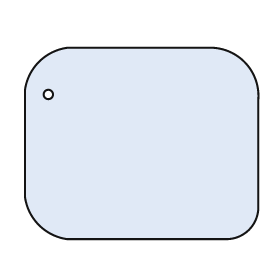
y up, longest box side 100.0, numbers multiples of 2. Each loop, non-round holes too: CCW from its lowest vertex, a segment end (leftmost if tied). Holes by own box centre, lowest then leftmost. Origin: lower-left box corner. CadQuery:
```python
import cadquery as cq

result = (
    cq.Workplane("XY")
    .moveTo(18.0, 0.0)
    .lineTo(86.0, 0.0)
    .threePointArc((96.0, 4.0), (100.0, 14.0))
    .lineTo(100.0, 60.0)
    .threePointArc((94.0, 76.0), (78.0, 82.0))
    .lineTo(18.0, 82.0)
    .threePointArc((6.0, 76.0), (0.0, 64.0))
    .lineTo(0.0, 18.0)
    .threePointArc((6.0, 6.0), (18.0, 0.0))
    .close()
    .moveTo(10.0, 62.0)
    .circle(2.0)
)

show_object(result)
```